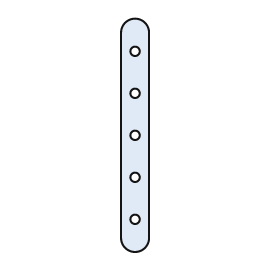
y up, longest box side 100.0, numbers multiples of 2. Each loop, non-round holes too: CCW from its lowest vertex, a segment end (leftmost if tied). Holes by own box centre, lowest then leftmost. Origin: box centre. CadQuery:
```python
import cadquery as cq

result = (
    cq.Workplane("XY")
    .moveTo(-6.0, -44.0)
    .threePointArc((0.0, -50.0), (6.0, -44.0))
    .lineTo(6.0, 44.0)
    .threePointArc((0.0, 50.0), (-6.0, 44.0))
    .close()
    .moveTo(0.0, -36.0)
    .circle(2.0)
    .moveTo(0.0, -18.0)
    .circle(2.0)
    .moveTo(0.0, 0.0)
    .circle(2.0)
    .moveTo(0.0, 18.0)
    .circle(2.0)
    .moveTo(0.0, 36.0)
    .circle(2.0)
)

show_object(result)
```